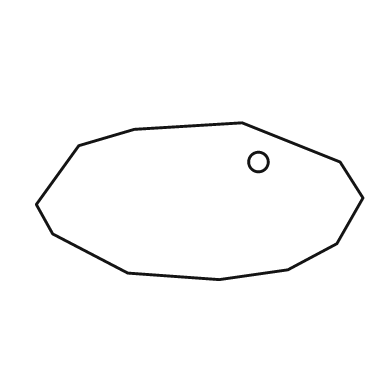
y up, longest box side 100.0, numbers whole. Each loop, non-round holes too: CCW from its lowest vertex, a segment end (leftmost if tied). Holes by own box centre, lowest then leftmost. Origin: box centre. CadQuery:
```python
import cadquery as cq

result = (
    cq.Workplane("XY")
    .moveTo(6.0, -24.0)
    .lineTo(27.0, -21.0)
    .lineTo(42.0, -13.0)
    .lineTo(50.0, 1.0)
    .lineTo(43.0, 12.0)
    .lineTo(13.0, 24.0)
    .lineTo(-20.0, 22.0)
    .lineTo(-37.0, 17.0)
    .lineTo(-50.0, -1.0)
    .lineTo(-45.0, -10.0)
    .lineTo(-22.0, -22.0)
    .close()
    .moveTo(18.0, 12.0)
    .circle(3.0)
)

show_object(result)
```